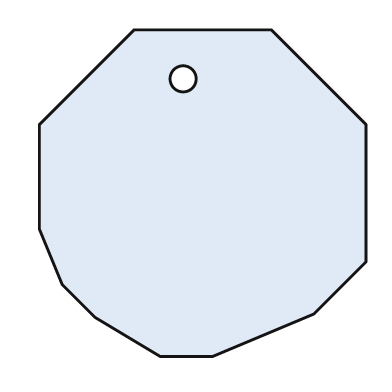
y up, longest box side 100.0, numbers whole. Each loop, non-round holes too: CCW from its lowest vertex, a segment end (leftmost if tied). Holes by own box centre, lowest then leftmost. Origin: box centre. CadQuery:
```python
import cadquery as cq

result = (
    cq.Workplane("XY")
    .moveTo(-13.0, -50.0)
    .lineTo(3.0, -50.0)
    .lineTo(34.0, -37.0)
    .lineTo(50.0, -21.0)
    .lineTo(50.0, 21.0)
    .lineTo(21.0, 50.0)
    .lineTo(-21.0, 50.0)
    .lineTo(-50.0, 21.0)
    .lineTo(-50.0, -11.0)
    .lineTo(-43.0, -28.0)
    .lineTo(-33.0, -38.0)
    .close()
    .moveTo(-6.0, 35.0)
    .circle(4.0)
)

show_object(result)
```